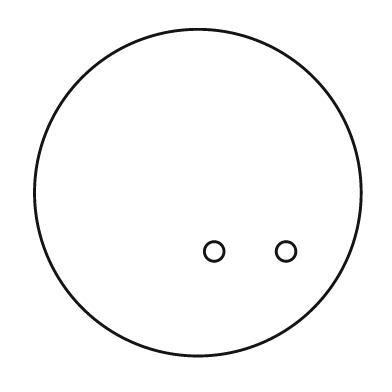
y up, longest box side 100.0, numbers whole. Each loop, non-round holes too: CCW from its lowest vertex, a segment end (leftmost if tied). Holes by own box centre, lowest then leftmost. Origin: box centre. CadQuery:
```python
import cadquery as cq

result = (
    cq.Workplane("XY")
    .moveTo(0.0, 0.0)
    .circle(50.0)
    .moveTo(5.0, -18.0)
    .circle(3.0)
    .moveTo(27.0, -18.0)
    .circle(3.0)
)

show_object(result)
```